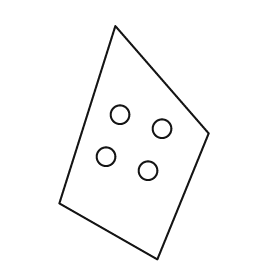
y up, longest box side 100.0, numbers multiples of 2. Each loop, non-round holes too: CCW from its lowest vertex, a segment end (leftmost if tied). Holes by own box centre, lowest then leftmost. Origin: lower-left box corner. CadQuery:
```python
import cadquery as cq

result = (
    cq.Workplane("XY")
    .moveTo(42.0, 0.0)
    .lineTo(64.0, 54.0)
    .lineTo(24.0, 100.0)
    .lineTo(0.0, 24.0)
    .close()
    .moveTo(38.0, 38.0)
    .circle(4.0)
    .moveTo(20.0, 44.0)
    .circle(4.0)
    .moveTo(44.0, 56.0)
    .circle(4.0)
    .moveTo(26.0, 62.0)
    .circle(4.0)
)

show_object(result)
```